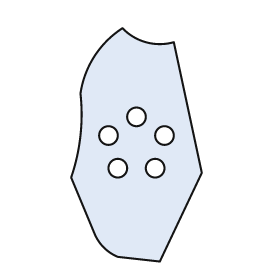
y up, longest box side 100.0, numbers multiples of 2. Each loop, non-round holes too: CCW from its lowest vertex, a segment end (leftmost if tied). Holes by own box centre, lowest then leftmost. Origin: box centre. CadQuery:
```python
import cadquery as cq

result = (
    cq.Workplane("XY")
    .moveTo(10.0, -50.0)
    .lineTo(28.0, -12.0)
    .lineTo(16.0, 44.0)
    .threePointArc((4.0, 44.0), (-6.0, 50.0))
    .threePointArc((-18.0, 38.0), (-24.0, 22.0))
    .threePointArc((-24.0, 4.0), (-28.0, -14.0))
    .lineTo(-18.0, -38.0)
    .threePointArc((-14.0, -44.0), (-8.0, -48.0))
    .close()
    .moveTo(-8.0, -10.0)
    .circle(4.0)
    .moveTo(8.0, -10.0)
    .circle(4.0)
    .moveTo(-12.0, 4.0)
    .circle(4.0)
    .moveTo(12.0, 4.0)
    .circle(4.0)
    .moveTo(0.0, 12.0)
    .circle(4.0)
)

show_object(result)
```